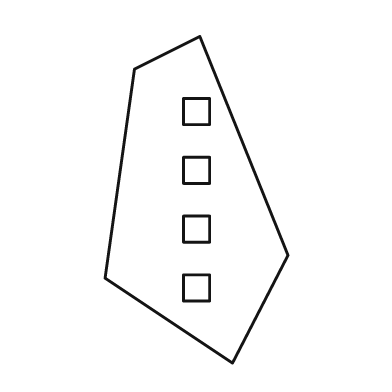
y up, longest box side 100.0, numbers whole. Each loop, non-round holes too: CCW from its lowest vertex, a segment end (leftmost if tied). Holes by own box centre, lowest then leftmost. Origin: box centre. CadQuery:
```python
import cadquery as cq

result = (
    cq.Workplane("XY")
    .moveTo(11.0, -50.0)
    .lineTo(28.0, -17.0)
    .lineTo(1.0, 50.0)
    .lineTo(-19.0, 40.0)
    .lineTo(-28.0, -24.0)
    .close()
    .moveTo(-4.0, -31.0)
    .lineTo(4.0, -31.0)
    .lineTo(4.0, -23.0)
    .lineTo(-4.0, -23.0)
    .close()
    .moveTo(-4.0, -13.0)
    .lineTo(4.0, -13.0)
    .lineTo(4.0, -5.0)
    .lineTo(-4.0, -5.0)
    .close()
    .moveTo(-4.0, 5.0)
    .lineTo(4.0, 5.0)
    .lineTo(4.0, 13.0)
    .lineTo(-4.0, 13.0)
    .close()
    .moveTo(-4.0, 23.0)
    .lineTo(4.0, 23.0)
    .lineTo(4.0, 31.0)
    .lineTo(-4.0, 31.0)
    .close()
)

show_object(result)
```